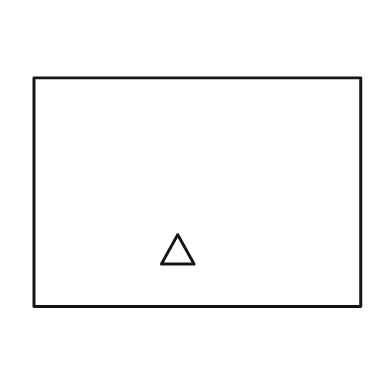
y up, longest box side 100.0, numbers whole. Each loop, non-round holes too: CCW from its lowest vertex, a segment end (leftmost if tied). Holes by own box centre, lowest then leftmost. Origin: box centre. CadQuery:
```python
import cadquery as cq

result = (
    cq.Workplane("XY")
    .moveTo(-50.0, -35.0)
    .lineTo(50.0, -35.0)
    .lineTo(50.0, 35.0)
    .lineTo(-50.0, 35.0)
    .close()
    .moveTo(-11.0, -22.0)
    .lineTo(-1.0, -22.0)
    .lineTo(-6.0, -13.0)
    .close()
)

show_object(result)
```